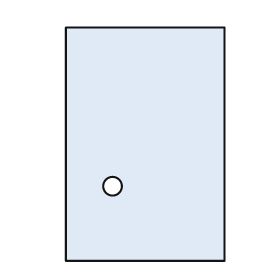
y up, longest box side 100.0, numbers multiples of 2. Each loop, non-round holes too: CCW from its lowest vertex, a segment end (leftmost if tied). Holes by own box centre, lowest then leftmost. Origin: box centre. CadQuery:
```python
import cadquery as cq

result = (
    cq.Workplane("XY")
    .moveTo(-34.0, -50.0)
    .lineTo(34.0, -50.0)
    .lineTo(34.0, 50.0)
    .lineTo(-34.0, 50.0)
    .close()
    .moveTo(-14.0, -18.0)
    .circle(4.0)
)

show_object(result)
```